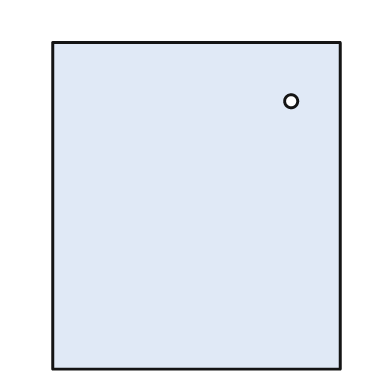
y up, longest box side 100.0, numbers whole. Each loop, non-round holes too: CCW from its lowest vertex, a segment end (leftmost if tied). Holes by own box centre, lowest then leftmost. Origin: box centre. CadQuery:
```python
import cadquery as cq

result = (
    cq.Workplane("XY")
    .moveTo(-44.0, -50.0)
    .lineTo(44.0, -50.0)
    .lineTo(44.0, 50.0)
    .lineTo(-44.0, 50.0)
    .close()
    .moveTo(29.0, 32.0)
    .circle(2.0)
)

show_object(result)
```